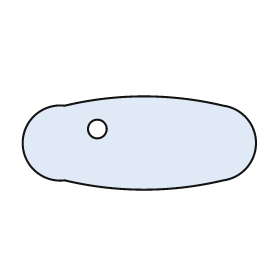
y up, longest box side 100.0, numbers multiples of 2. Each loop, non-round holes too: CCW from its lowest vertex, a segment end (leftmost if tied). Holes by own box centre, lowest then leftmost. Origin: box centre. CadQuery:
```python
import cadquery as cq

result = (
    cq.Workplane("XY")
    .moveTo(-32.0, -16.0)
    .threePointArc((2.0, -20.0), (36.0, -16.0))
    .threePointArc((50.0, 0.0), (36.0, 16.0))
    .threePointArc((2.0, 20.0), (-32.0, 16.0))
    .threePointArc((-50.0, 0.0), (-32.0, -16.0))
    .close()
    .moveTo(-18.0, 6.0)
    .circle(4.0)
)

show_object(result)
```